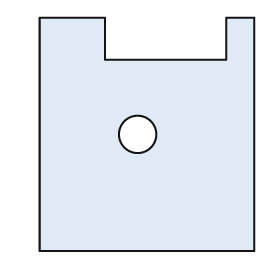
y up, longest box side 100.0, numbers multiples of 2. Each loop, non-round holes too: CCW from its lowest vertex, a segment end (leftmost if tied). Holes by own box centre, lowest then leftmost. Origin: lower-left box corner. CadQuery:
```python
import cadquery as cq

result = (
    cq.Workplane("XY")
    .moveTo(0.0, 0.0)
    .lineTo(92.0, 0.0)
    .lineTo(92.0, 100.0)
    .lineTo(80.0, 100.0)
    .lineTo(80.0, 82.0)
    .lineTo(28.0, 82.0)
    .lineTo(28.0, 100.0)
    .lineTo(0.0, 100.0)
    .close()
    .moveTo(42.0, 50.0)
    .circle(8.0)
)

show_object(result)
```